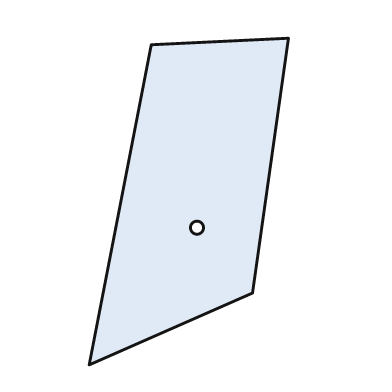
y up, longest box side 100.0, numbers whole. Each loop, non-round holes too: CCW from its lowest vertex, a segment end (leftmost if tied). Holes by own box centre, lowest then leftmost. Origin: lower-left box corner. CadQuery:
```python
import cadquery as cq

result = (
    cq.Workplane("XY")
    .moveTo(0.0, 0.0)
    .lineTo(50.0, 22.0)
    .lineTo(61.0, 100.0)
    .lineTo(19.0, 98.0)
    .close()
    .moveTo(33.0, 42.0)
    .circle(2.0)
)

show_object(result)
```